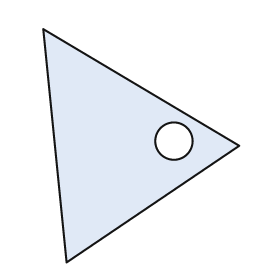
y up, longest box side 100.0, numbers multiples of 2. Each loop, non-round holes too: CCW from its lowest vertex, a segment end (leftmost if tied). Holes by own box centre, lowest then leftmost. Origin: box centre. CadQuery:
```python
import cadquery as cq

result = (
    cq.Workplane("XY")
    .moveTo(-32.0, -50.0)
    .lineTo(42.0, 0.0)
    .lineTo(-42.0, 50.0)
    .close()
    .moveTo(14.0, 2.0)
    .circle(8.0)
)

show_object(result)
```